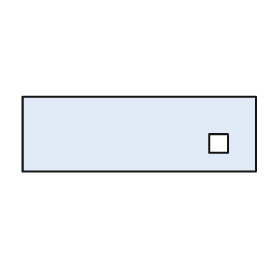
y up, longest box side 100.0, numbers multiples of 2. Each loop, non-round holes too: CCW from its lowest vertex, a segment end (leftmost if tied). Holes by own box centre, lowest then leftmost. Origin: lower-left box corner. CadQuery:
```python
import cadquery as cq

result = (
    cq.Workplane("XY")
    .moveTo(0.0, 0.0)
    .lineTo(100.0, 0.0)
    .lineTo(100.0, 32.0)
    .lineTo(0.0, 32.0)
    .close()
    .moveTo(80.0, 8.0)
    .lineTo(88.0, 8.0)
    .lineTo(88.0, 16.0)
    .lineTo(80.0, 16.0)
    .close()
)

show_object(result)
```